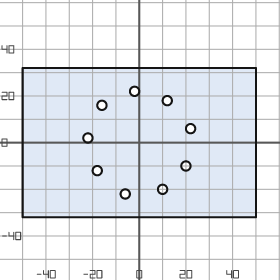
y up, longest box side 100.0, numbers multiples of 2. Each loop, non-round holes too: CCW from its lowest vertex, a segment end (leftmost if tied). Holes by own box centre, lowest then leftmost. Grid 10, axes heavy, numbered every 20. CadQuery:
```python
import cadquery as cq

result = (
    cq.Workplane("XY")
    .moveTo(-50.0, -32.0)
    .lineTo(50.0, -32.0)
    .lineTo(50.0, 32.0)
    .lineTo(-50.0, 32.0)
    .close()
    .moveTo(-6.0, -22.0)
    .circle(2.0)
    .moveTo(10.0, -20.0)
    .circle(2.0)
    .moveTo(-18.0, -12.0)
    .circle(2.0)
    .moveTo(20.0, -10.0)
    .circle(2.0)
    .moveTo(-22.0, 2.0)
    .circle(2.0)
    .moveTo(22.0, 6.0)
    .circle(2.0)
    .moveTo(-16.0, 16.0)
    .circle(2.0)
    .moveTo(12.0, 18.0)
    .circle(2.0)
    .moveTo(-2.0, 22.0)
    .circle(2.0)
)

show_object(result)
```